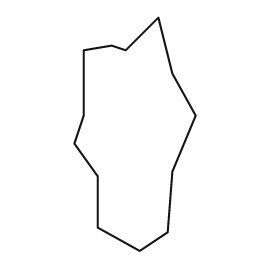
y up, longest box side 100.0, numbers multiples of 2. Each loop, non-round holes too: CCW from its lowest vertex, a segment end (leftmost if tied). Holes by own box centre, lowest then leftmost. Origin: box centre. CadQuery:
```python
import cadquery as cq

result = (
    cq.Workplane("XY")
    .moveTo(2.0, -50.0)
    .lineTo(14.0, -42.0)
    .lineTo(16.0, -16.0)
    .lineTo(26.0, 8.0)
    .lineTo(16.0, 26.0)
    .lineTo(10.0, 50.0)
    .lineTo(-4.0, 36.0)
    .lineTo(-10.0, 38.0)
    .lineTo(-22.0, 36.0)
    .lineTo(-22.0, 8.0)
    .lineTo(-26.0, -4.0)
    .lineTo(-16.0, -18.0)
    .lineTo(-16.0, -40.0)
    .close()
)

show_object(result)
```